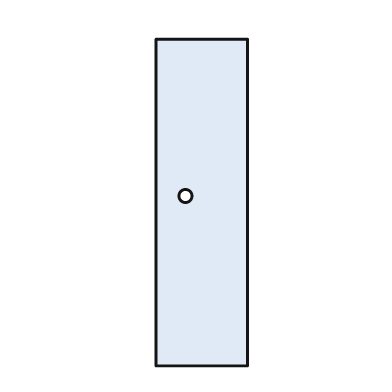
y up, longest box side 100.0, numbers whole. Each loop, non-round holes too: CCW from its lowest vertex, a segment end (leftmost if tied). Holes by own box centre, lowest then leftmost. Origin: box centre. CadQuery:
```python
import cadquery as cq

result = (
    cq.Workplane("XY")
    .moveTo(-14.0, -50.0)
    .lineTo(14.0, -50.0)
    .lineTo(14.0, 50.0)
    .lineTo(-14.0, 50.0)
    .close()
    .moveTo(-5.0, 2.0)
    .circle(2.0)
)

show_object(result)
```